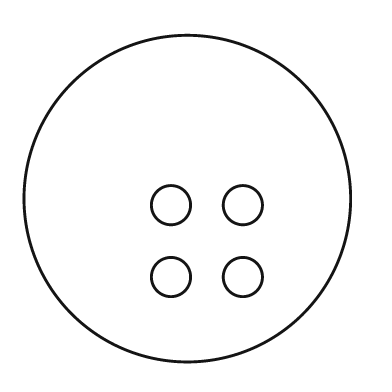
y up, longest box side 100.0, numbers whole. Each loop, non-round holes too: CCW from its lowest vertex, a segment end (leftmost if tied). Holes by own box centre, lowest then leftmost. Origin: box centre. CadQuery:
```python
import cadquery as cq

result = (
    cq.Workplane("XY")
    .moveTo(0.0, 0.0)
    .circle(50.0)
    .moveTo(-5.0, -24.0)
    .circle(6.0)
    .moveTo(17.0, -24.0)
    .circle(6.0)
    .moveTo(-5.0, -2.0)
    .circle(6.0)
    .moveTo(17.0, -2.0)
    .circle(6.0)
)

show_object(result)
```